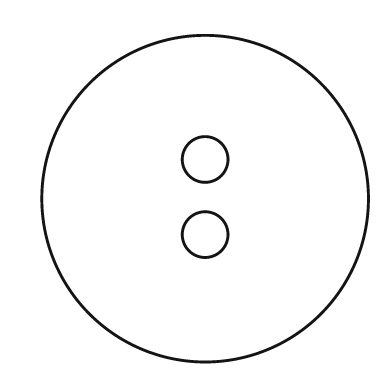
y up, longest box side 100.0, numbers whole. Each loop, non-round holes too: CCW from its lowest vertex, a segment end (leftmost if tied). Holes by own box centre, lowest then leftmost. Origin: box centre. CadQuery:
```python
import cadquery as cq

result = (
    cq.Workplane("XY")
    .moveTo(0.0, 0.0)
    .circle(50.0)
    .moveTo(0.0, -11.0)
    .circle(7.0)
    .moveTo(0.0, 12.0)
    .circle(7.0)
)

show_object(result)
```